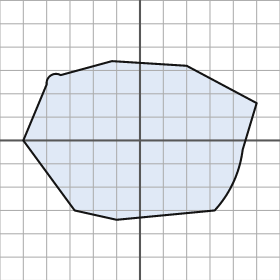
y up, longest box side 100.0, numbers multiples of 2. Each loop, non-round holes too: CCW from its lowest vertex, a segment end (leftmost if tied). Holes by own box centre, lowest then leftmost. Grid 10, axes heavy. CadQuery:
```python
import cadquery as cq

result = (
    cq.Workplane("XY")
    .moveTo(-10.0, -34.0)
    .lineTo(32.0, -30.0)
    .threePointArc((40.0, -18.0), (44.0, -4.0))
    .lineTo(50.0, 16.0)
    .lineTo(20.0, 32.0)
    .lineTo(-12.0, 34.0)
    .lineTo(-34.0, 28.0)
    .threePointArc((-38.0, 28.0), (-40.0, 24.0))
    .lineTo(-50.0, 0.0)
    .lineTo(-28.0, -30.0)
    .close()
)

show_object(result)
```